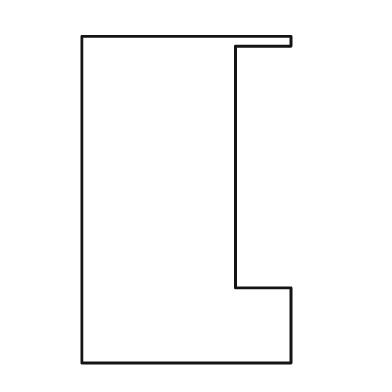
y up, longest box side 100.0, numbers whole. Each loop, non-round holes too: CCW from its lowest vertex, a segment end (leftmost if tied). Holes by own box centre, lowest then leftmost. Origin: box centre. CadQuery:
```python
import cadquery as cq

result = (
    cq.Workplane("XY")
    .moveTo(-32.0, -50.0)
    .lineTo(32.0, -50.0)
    .lineTo(32.0, -27.0)
    .lineTo(15.0, -27.0)
    .lineTo(15.0, 47.0)
    .lineTo(32.0, 47.0)
    .lineTo(32.0, 50.0)
    .lineTo(-32.0, 50.0)
    .close()
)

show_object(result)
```